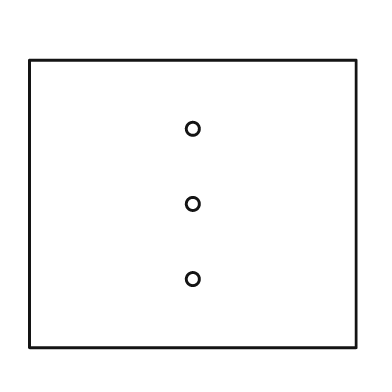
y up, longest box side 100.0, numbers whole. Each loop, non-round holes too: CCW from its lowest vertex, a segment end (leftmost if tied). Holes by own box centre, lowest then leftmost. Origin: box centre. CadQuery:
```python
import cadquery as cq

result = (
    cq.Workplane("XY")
    .moveTo(-50.0, -44.0)
    .lineTo(50.0, -44.0)
    .lineTo(50.0, 44.0)
    .lineTo(-50.0, 44.0)
    .close()
    .moveTo(0.0, -23.0)
    .circle(2.0)
    .moveTo(0.0, 0.0)
    .circle(2.0)
    .moveTo(0.0, 23.0)
    .circle(2.0)
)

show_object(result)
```